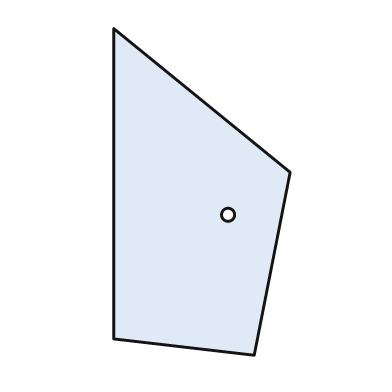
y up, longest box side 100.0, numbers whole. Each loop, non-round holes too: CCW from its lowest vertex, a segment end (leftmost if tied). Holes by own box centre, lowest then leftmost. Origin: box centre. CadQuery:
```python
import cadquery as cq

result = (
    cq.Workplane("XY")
    .moveTo(16.0, -50.0)
    .lineTo(27.0, 6.0)
    .lineTo(-27.0, 50.0)
    .lineTo(-27.0, -45.0)
    .close()
    .moveTo(8.0, -7.0)
    .circle(2.0)
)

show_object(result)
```